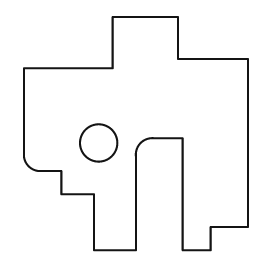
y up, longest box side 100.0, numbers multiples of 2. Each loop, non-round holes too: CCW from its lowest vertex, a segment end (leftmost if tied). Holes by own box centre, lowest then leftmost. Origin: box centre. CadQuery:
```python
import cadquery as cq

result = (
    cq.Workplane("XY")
    .moveTo(-18.0, -50.0)
    .lineTo(0.0, -50.0)
    .lineTo(0.0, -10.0)
    .threePointArc((2.0, -4.0), (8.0, -2.0))
    .lineTo(20.0, -2.0)
    .lineTo(20.0, -50.0)
    .lineTo(32.0, -50.0)
    .lineTo(32.0, -40.0)
    .lineTo(48.0, -40.0)
    .lineTo(48.0, 32.0)
    .lineTo(18.0, 32.0)
    .lineTo(18.0, 50.0)
    .lineTo(-10.0, 50.0)
    .lineTo(-10.0, 28.0)
    .lineTo(-48.0, 28.0)
    .lineTo(-48.0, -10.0)
    .threePointArc((-46.0, -14.0), (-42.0, -16.0))
    .lineTo(-32.0, -16.0)
    .lineTo(-32.0, -26.0)
    .lineTo(-18.0, -26.0)
    .close()
    .moveTo(-16.0, -4.0)
    .circle(8.0)
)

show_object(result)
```